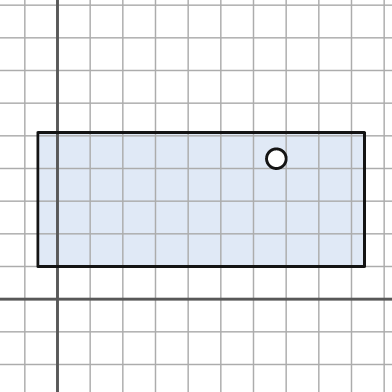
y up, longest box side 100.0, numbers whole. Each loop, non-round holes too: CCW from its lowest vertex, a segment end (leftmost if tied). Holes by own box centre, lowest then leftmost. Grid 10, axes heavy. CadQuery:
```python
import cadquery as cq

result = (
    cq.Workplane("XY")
    .moveTo(-6.0, 10.0)
    .lineTo(94.0, 10.0)
    .lineTo(94.0, 51.0)
    .lineTo(-6.0, 51.0)
    .close()
    .moveTo(67.0, 43.0)
    .circle(3.0)
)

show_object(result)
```